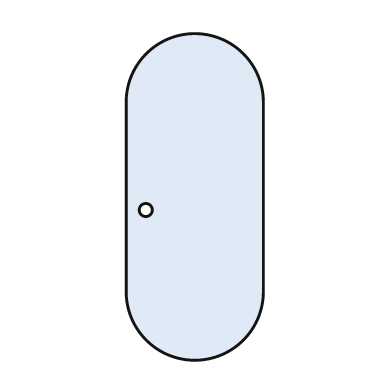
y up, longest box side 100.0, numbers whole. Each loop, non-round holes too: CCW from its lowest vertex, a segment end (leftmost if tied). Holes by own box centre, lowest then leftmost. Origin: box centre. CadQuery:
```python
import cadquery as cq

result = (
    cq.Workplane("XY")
    .moveTo(-21.0, -29.0)
    .threePointArc((0.0, -50.0), (21.0, -29.0))
    .lineTo(21.0, 29.0)
    .threePointArc((0.0, 50.0), (-21.0, 29.0))
    .close()
    .moveTo(-15.0, -4.0)
    .circle(2.0)
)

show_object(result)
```